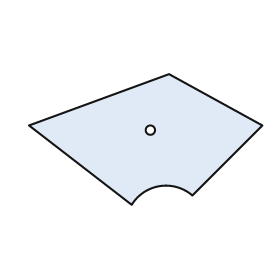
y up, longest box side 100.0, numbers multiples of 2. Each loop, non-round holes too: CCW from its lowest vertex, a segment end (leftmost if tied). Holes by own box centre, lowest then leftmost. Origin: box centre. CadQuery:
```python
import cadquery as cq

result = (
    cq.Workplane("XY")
    .moveTo(-6.0, -28.0)
    .threePointArc((6.0, -20.0), (20.0, -24.0))
    .lineTo(50.0, 6.0)
    .lineTo(10.0, 28.0)
    .lineTo(-50.0, 6.0)
    .close()
    .moveTo(2.0, 4.0)
    .circle(2.0)
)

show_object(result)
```